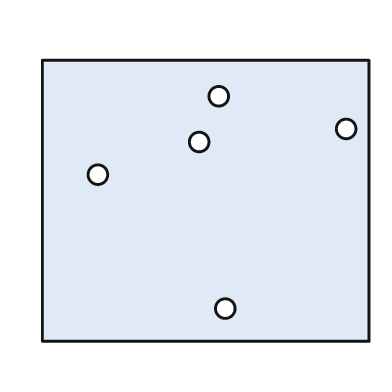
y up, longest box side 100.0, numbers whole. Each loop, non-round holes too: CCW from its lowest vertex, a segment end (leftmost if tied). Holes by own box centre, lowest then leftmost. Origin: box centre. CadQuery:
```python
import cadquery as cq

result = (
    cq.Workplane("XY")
    .moveTo(-50.0, -43.0)
    .lineTo(50.0, -43.0)
    .lineTo(50.0, 43.0)
    .lineTo(-50.0, 43.0)
    .close()
    .moveTo(6.0, -33.0)
    .circle(3.0)
    .moveTo(-33.0, 8.0)
    .circle(3.0)
    .moveTo(-2.0, 18.0)
    .circle(3.0)
    .moveTo(43.0, 22.0)
    .circle(3.0)
    .moveTo(4.0, 32.0)
    .circle(3.0)
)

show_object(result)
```